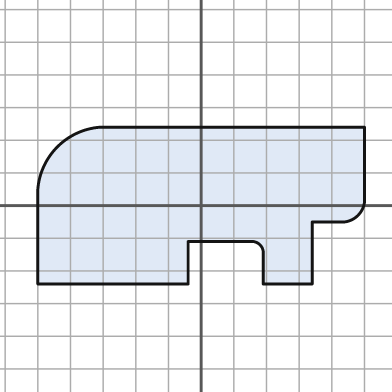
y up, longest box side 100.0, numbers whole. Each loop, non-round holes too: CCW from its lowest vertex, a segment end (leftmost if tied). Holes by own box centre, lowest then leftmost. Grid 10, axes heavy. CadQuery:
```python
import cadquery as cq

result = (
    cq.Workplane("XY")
    .moveTo(-50.0, -24.0)
    .lineTo(-4.0, -24.0)
    .lineTo(-4.0, -11.0)
    .lineTo(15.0, -11.0)
    .threePointArc((18.0, -12.0), (19.0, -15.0))
    .lineTo(19.0, -24.0)
    .lineTo(34.0, -24.0)
    .lineTo(34.0, -5.0)
    .lineTo(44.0, -5.0)
    .threePointArc((48.0, -3.0), (50.0, 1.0))
    .lineTo(50.0, 24.0)
    .lineTo(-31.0, 24.0)
    .threePointArc((-44.0, 18.0), (-50.0, 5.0))
    .close()
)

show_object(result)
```